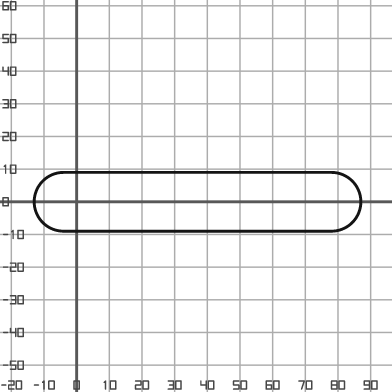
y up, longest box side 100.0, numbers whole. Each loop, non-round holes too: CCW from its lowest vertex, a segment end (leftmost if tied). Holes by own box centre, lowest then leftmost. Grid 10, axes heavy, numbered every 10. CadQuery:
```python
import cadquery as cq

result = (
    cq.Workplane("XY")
    .moveTo(-4.0, -9.0)
    .lineTo(78.0, -9.0)
    .threePointArc((87.0, 0.0), (78.0, 9.0))
    .lineTo(-4.0, 9.0)
    .threePointArc((-13.0, 0.0), (-4.0, -9.0))
    .close()
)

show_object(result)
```